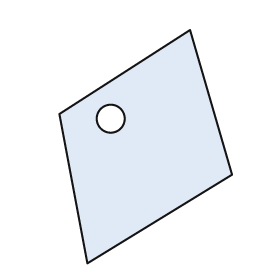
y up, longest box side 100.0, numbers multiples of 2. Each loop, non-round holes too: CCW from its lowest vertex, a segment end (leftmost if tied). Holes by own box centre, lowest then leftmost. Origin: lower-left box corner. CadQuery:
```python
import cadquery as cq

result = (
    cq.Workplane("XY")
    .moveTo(12.0, 0.0)
    .lineTo(74.0, 38.0)
    .lineTo(56.0, 100.0)
    .lineTo(0.0, 64.0)
    .close()
    .moveTo(22.0, 62.0)
    .circle(6.0)
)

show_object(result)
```